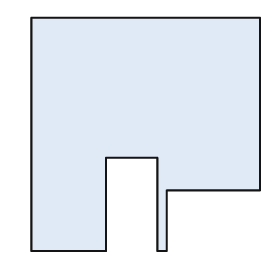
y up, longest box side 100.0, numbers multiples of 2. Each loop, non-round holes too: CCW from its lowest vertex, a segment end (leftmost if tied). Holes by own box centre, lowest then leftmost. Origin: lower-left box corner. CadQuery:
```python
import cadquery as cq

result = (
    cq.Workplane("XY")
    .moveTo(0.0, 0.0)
    .lineTo(32.0, 0.0)
    .lineTo(32.0, 40.0)
    .lineTo(54.0, 40.0)
    .lineTo(54.0, 0.0)
    .lineTo(58.0, 0.0)
    .lineTo(58.0, 26.0)
    .lineTo(98.0, 26.0)
    .lineTo(98.0, 100.0)
    .lineTo(0.0, 100.0)
    .close()
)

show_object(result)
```